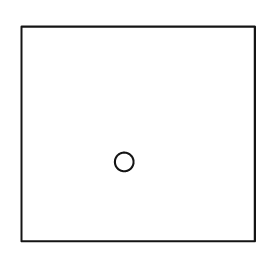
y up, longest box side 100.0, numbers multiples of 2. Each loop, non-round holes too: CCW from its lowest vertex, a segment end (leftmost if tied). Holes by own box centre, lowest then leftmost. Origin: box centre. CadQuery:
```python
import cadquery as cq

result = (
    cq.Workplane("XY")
    .moveTo(-50.0, -46.0)
    .lineTo(50.0, -46.0)
    .lineTo(50.0, 46.0)
    .lineTo(-50.0, 46.0)
    .close()
    .moveTo(-6.0, -12.0)
    .circle(4.0)
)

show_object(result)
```